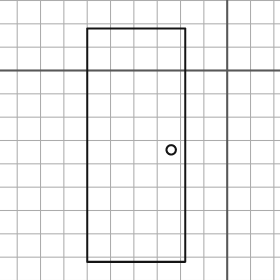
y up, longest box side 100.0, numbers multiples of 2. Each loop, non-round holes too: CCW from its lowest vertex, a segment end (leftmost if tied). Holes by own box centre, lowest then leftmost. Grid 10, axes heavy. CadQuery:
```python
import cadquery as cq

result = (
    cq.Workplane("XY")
    .moveTo(-60.0, -82.0)
    .lineTo(-18.0, -82.0)
    .lineTo(-18.0, 18.0)
    .lineTo(-60.0, 18.0)
    .close()
    .moveTo(-24.0, -34.0)
    .circle(2.0)
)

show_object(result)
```